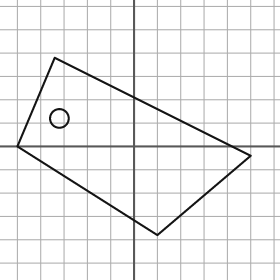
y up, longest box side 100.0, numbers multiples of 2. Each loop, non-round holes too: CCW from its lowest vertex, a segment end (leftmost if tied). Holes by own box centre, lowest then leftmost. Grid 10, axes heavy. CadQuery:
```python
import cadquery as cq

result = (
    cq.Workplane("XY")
    .moveTo(10.0, -38.0)
    .lineTo(50.0, -4.0)
    .lineTo(-34.0, 38.0)
    .lineTo(-50.0, 0.0)
    .close()
    .moveTo(-32.0, 12.0)
    .circle(4.0)
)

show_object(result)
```